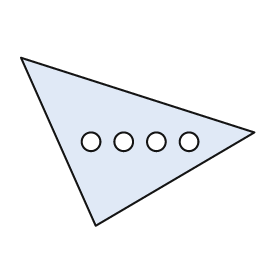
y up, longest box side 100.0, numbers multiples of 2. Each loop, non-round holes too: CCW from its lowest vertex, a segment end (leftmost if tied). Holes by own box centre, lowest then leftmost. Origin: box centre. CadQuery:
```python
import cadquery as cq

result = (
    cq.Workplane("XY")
    .moveTo(-18.0, -36.0)
    .lineTo(50.0, 4.0)
    .lineTo(-50.0, 36.0)
    .close()
    .moveTo(-20.0, 0.0)
    .circle(4.0)
    .moveTo(-6.0, 0.0)
    .circle(4.0)
    .moveTo(8.0, 0.0)
    .circle(4.0)
    .moveTo(22.0, 0.0)
    .circle(4.0)
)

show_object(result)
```